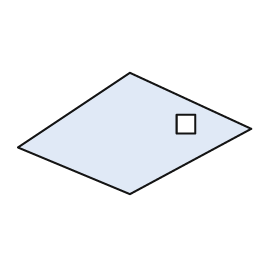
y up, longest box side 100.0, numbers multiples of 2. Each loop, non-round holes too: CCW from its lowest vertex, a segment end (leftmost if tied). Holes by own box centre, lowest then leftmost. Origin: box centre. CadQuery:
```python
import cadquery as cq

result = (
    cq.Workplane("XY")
    .moveTo(-2.0, -26.0)
    .lineTo(50.0, 2.0)
    .lineTo(-2.0, 26.0)
    .lineTo(-50.0, -6.0)
    .close()
    .moveTo(18.0, 0.0)
    .lineTo(26.0, 0.0)
    .lineTo(26.0, 8.0)
    .lineTo(18.0, 8.0)
    .close()
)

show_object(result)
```